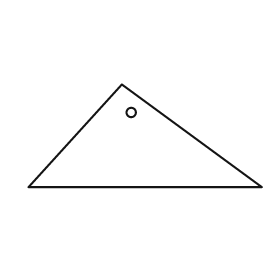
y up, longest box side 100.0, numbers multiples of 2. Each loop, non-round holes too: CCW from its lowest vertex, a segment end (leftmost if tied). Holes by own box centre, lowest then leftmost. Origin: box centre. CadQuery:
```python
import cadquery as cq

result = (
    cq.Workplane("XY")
    .moveTo(-50.0, -22.0)
    .lineTo(50.0, -22.0)
    .lineTo(-10.0, 22.0)
    .close()
    .moveTo(-6.0, 10.0)
    .circle(2.0)
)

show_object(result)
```